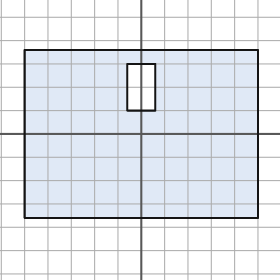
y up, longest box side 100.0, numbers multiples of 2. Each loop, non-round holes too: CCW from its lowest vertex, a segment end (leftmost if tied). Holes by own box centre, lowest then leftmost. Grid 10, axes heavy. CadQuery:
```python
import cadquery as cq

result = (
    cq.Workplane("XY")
    .moveTo(-50.0, -36.0)
    .lineTo(50.0, -36.0)
    .lineTo(50.0, 36.0)
    .lineTo(-50.0, 36.0)
    .close()
    .moveTo(-6.0, 10.0)
    .lineTo(6.0, 10.0)
    .lineTo(6.0, 30.0)
    .lineTo(-6.0, 30.0)
    .close()
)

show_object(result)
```